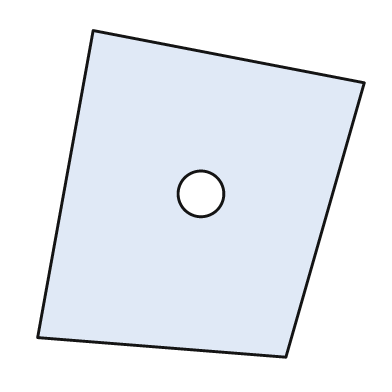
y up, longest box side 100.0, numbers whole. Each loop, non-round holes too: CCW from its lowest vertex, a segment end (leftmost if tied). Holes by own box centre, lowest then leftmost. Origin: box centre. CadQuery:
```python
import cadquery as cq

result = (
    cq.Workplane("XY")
    .moveTo(26.0, -50.0)
    .lineTo(50.0, 34.0)
    .lineTo(-33.0, 50.0)
    .lineTo(-50.0, -44.0)
    .close()
    .moveTo(0.0, 0.0)
    .circle(7.0)
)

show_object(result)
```